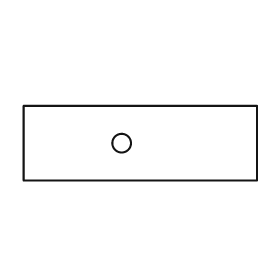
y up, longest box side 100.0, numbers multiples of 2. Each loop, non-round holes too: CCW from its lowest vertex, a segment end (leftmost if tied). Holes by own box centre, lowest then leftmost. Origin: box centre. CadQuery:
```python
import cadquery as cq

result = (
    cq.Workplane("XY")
    .moveTo(-50.0, -16.0)
    .lineTo(50.0, -16.0)
    .lineTo(50.0, 16.0)
    .lineTo(-50.0, 16.0)
    .close()
    .moveTo(-8.0, 0.0)
    .circle(4.0)
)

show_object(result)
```